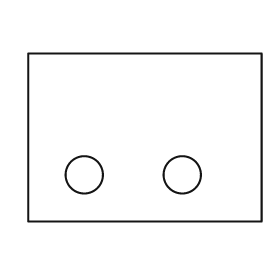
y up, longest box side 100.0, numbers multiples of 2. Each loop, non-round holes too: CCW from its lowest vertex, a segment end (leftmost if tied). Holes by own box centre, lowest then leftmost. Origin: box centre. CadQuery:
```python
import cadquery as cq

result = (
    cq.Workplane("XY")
    .moveTo(-50.0, -36.0)
    .lineTo(50.0, -36.0)
    .lineTo(50.0, 36.0)
    .lineTo(-50.0, 36.0)
    .close()
    .moveTo(-26.0, -16.0)
    .circle(8.0)
    .moveTo(16.0, -16.0)
    .circle(8.0)
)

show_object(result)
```